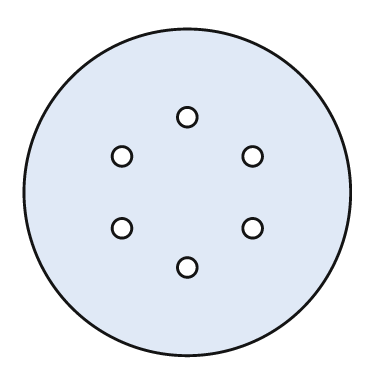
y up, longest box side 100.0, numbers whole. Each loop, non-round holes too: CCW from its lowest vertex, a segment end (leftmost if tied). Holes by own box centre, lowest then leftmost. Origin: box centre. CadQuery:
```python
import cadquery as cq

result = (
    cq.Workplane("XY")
    .moveTo(0.0, 0.0)
    .circle(50.0)
    .moveTo(0.0, -23.0)
    .circle(3.0)
    .moveTo(-20.0, -11.0)
    .circle(3.0)
    .moveTo(20.0, -11.0)
    .circle(3.0)
    .moveTo(-20.0, 11.0)
    .circle(3.0)
    .moveTo(20.0, 11.0)
    .circle(3.0)
    .moveTo(0.0, 23.0)
    .circle(3.0)
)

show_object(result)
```